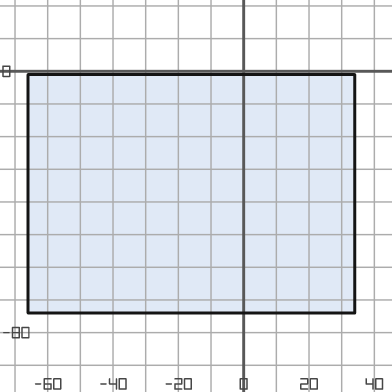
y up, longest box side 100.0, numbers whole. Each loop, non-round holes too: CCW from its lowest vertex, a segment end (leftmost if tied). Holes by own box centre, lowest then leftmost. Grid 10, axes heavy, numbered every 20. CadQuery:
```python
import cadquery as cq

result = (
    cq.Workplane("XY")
    .moveTo(-66.0, -74.0)
    .lineTo(34.0, -74.0)
    .lineTo(34.0, -1.0)
    .lineTo(-66.0, -1.0)
    .close()
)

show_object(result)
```